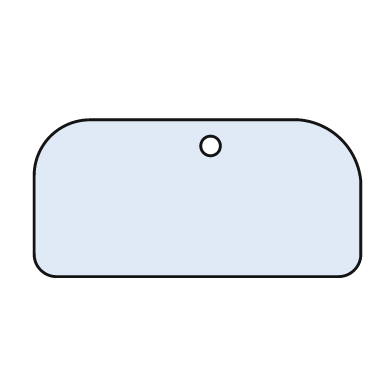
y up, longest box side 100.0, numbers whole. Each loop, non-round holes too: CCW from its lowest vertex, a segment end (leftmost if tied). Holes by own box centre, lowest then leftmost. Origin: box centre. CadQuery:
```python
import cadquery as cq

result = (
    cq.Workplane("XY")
    .moveTo(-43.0, -24.0)
    .lineTo(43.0, -24.0)
    .threePointArc((48.0, -22.0), (50.0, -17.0))
    .lineTo(50.0, 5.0)
    .threePointArc((44.0, 18.0), (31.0, 24.0))
    .lineTo(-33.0, 24.0)
    .threePointArc((-45.0, 19.0), (-50.0, 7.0))
    .lineTo(-50.0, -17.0)
    .threePointArc((-48.0, -22.0), (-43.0, -24.0))
    .close()
    .moveTo(4.0, 16.0)
    .circle(3.0)
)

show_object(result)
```